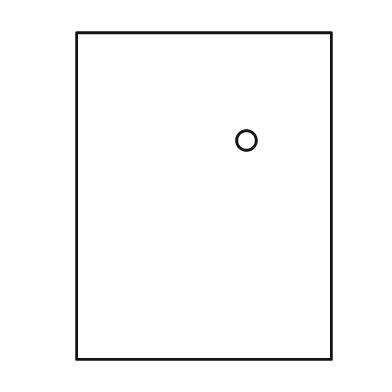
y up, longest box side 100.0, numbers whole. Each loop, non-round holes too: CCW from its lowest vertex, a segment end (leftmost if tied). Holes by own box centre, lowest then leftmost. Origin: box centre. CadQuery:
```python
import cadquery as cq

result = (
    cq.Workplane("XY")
    .moveTo(-39.0, -50.0)
    .lineTo(39.0, -50.0)
    .lineTo(39.0, 50.0)
    .lineTo(-39.0, 50.0)
    .close()
    .moveTo(13.0, 17.0)
    .circle(3.0)
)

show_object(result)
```